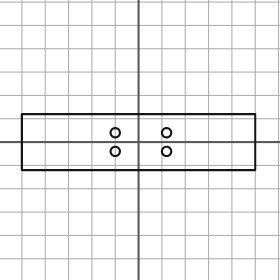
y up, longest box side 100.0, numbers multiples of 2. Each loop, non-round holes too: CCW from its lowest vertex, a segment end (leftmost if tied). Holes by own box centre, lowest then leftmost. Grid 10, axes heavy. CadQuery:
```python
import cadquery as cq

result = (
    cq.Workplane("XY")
    .moveTo(-50.0, -12.0)
    .lineTo(50.0, -12.0)
    .lineTo(50.0, 12.0)
    .lineTo(-50.0, 12.0)
    .close()
    .moveTo(-10.0, -4.0)
    .circle(2.0)
    .moveTo(12.0, -4.0)
    .circle(2.0)
    .moveTo(-10.0, 4.0)
    .circle(2.0)
    .moveTo(12.0, 4.0)
    .circle(2.0)
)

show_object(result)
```